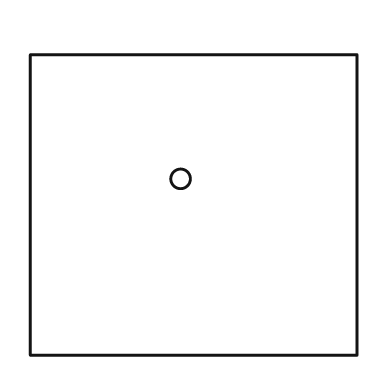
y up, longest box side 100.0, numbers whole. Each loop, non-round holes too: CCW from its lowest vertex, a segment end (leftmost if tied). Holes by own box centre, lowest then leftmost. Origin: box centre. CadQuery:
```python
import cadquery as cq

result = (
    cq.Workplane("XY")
    .moveTo(-50.0, -46.0)
    .lineTo(50.0, -46.0)
    .lineTo(50.0, 46.0)
    .lineTo(-50.0, 46.0)
    .close()
    .moveTo(-4.0, 8.0)
    .circle(3.0)
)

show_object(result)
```